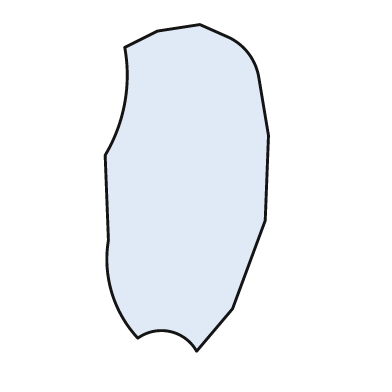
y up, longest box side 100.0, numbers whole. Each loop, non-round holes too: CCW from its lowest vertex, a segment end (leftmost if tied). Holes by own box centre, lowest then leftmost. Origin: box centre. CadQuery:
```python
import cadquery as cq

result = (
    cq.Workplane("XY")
    .moveTo(3.0, -50.0)
    .lineTo(14.0, -37.0)
    .lineTo(24.0, -10.0)
    .lineTo(25.0, 16.0)
    .lineTo(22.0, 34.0)
    .threePointArc((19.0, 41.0), (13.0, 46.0))
    .lineTo(4.0, 50.0)
    .lineTo(-9.0, 48.0)
    .lineTo(-19.0, 43.0)
    .threePointArc((-19.0, 26.0), (-25.0, 10.0))
    .lineTo(-24.0, -16.0)
    .threePointArc((-23.0, -32.0), (-15.0, -46.0))
    .threePointArc((-5.0, -44.0), (3.0, -50.0))
    .close()
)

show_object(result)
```